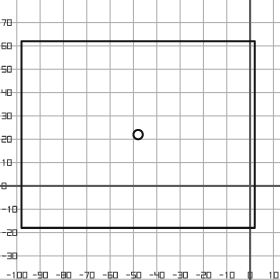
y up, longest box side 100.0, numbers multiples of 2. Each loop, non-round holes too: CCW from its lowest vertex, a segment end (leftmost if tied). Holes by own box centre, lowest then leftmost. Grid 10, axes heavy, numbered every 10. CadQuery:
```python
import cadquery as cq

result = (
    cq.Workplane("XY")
    .moveTo(-98.0, -18.0)
    .lineTo(2.0, -18.0)
    .lineTo(2.0, 62.0)
    .lineTo(-98.0, 62.0)
    .close()
    .moveTo(-48.0, 22.0)
    .circle(2.0)
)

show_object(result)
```